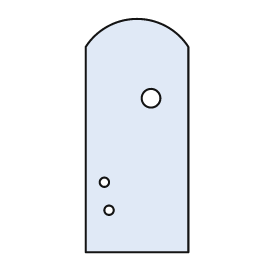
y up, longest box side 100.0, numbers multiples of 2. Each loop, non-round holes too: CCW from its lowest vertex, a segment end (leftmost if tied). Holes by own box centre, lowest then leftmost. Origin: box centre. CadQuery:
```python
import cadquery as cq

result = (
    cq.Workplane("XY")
    .moveTo(-22.0, -50.0)
    .lineTo(22.0, -50.0)
    .lineTo(22.0, 38.0)
    .threePointArc((0.0, 50.0), (-22.0, 38.0))
    .close()
    .moveTo(-12.0, -32.0)
    .circle(2.0)
    .moveTo(-14.0, -20.0)
    .circle(2.0)
    .moveTo(6.0, 16.0)
    .circle(4.0)
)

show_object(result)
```